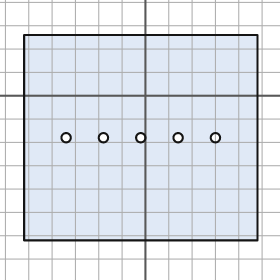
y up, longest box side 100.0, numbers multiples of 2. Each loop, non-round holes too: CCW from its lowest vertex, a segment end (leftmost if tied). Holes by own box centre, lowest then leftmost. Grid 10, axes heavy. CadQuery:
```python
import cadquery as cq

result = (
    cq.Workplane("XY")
    .moveTo(-52.0, -62.0)
    .lineTo(48.0, -62.0)
    .lineTo(48.0, 26.0)
    .lineTo(-52.0, 26.0)
    .close()
    .moveTo(-34.0, -18.0)
    .circle(2.0)
    .moveTo(-18.0, -18.0)
    .circle(2.0)
    .moveTo(-2.0, -18.0)
    .circle(2.0)
    .moveTo(14.0, -18.0)
    .circle(2.0)
    .moveTo(30.0, -18.0)
    .circle(2.0)
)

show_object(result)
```